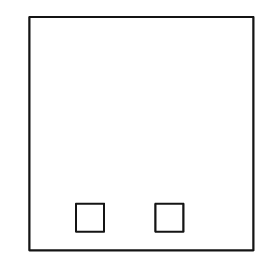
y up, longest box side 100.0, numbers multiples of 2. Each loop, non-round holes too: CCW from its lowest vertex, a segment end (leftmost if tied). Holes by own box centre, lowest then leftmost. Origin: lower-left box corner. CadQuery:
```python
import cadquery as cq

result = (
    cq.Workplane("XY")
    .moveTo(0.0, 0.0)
    .lineTo(96.0, 0.0)
    .lineTo(96.0, 100.0)
    .lineTo(0.0, 100.0)
    .close()
    .moveTo(20.0, 8.0)
    .lineTo(32.0, 8.0)
    .lineTo(32.0, 20.0)
    .lineTo(20.0, 20.0)
    .close()
    .moveTo(54.0, 8.0)
    .lineTo(66.0, 8.0)
    .lineTo(66.0, 20.0)
    .lineTo(54.0, 20.0)
    .close()
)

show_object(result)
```